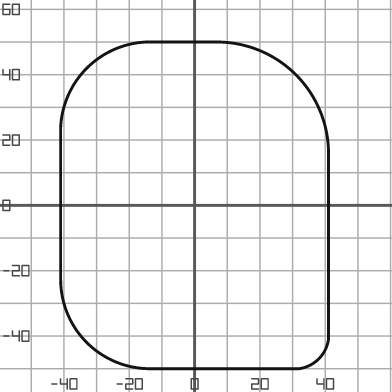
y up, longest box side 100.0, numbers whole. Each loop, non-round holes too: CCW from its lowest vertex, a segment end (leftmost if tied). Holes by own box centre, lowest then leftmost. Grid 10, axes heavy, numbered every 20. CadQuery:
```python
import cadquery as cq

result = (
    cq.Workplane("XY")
    .moveTo(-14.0, -50.0)
    .lineTo(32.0, -50.0)
    .threePointArc((38.0, -47.0), (41.0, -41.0))
    .lineTo(41.0, 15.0)
    .threePointArc((31.0, 40.0), (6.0, 50.0))
    .lineTo(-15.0, 50.0)
    .threePointArc((-33.0, 42.0), (-41.0, 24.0))
    .lineTo(-41.0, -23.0)
    .threePointArc((-33.0, -42.0), (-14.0, -50.0))
    .close()
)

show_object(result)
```